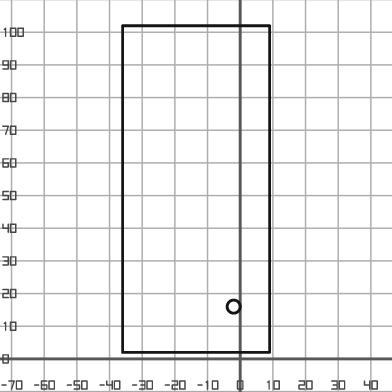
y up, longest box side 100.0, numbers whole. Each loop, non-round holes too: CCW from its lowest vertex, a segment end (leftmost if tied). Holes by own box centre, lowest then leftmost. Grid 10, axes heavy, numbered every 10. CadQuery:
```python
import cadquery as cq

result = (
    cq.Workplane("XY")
    .moveTo(-36.0, 2.0)
    .lineTo(9.0, 2.0)
    .lineTo(9.0, 102.0)
    .lineTo(-36.0, 102.0)
    .close()
    .moveTo(-2.0, 16.0)
    .circle(2.0)
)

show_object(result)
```